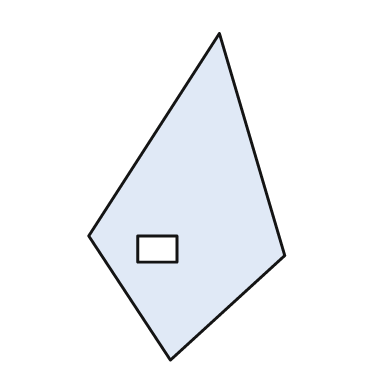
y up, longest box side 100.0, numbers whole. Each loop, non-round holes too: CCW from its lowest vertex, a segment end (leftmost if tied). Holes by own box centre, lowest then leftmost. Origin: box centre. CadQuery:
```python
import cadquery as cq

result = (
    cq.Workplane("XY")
    .moveTo(-5.0, -50.0)
    .lineTo(30.0, -18.0)
    .lineTo(10.0, 50.0)
    .lineTo(-30.0, -12.0)
    .close()
    .moveTo(-15.0, -20.0)
    .lineTo(-3.0, -20.0)
    .lineTo(-3.0, -12.0)
    .lineTo(-15.0, -12.0)
    .close()
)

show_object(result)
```